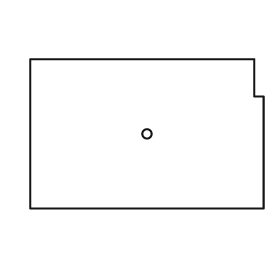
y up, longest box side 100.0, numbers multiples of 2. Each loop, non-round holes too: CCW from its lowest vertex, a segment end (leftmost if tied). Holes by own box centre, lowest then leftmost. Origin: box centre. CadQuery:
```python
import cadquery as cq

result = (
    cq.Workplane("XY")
    .moveTo(-50.0, -32.0)
    .lineTo(50.0, -32.0)
    .lineTo(50.0, 16.0)
    .lineTo(46.0, 16.0)
    .lineTo(46.0, 32.0)
    .lineTo(-50.0, 32.0)
    .close()
    .moveTo(0.0, 0.0)
    .circle(2.0)
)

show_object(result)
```